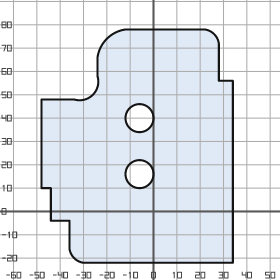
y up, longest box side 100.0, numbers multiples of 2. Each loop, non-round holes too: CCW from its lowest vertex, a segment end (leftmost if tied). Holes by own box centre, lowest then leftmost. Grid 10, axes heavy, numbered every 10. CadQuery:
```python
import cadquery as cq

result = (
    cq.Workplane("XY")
    .moveTo(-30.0, -22.0)
    .lineTo(34.0, -22.0)
    .lineTo(34.0, 56.0)
    .lineTo(28.0, 56.0)
    .lineTo(28.0, 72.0)
    .threePointArc((26.0, 76.0), (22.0, 78.0))
    .lineTo(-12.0, 78.0)
    .threePointArc((-20.0, 74.0), (-24.0, 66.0))
    .lineTo(-24.0, 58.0)
    .threePointArc((-26.0, 50.0), (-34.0, 48.0))
    .lineTo(-48.0, 48.0)
    .lineTo(-48.0, 10.0)
    .lineTo(-44.0, 10.0)
    .lineTo(-44.0, -4.0)
    .lineTo(-36.0, -4.0)
    .lineTo(-36.0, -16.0)
    .threePointArc((-34.0, -20.0), (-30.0, -22.0))
    .close()
    .moveTo(-6.0, 16.0)
    .circle(6.0)
    .moveTo(-6.0, 40.0)
    .circle(6.0)
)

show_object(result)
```